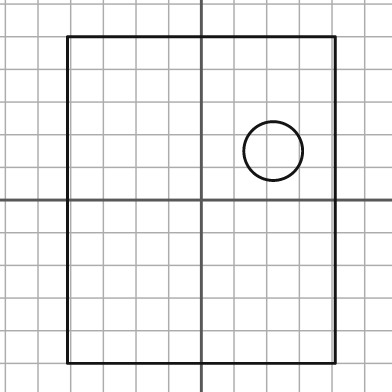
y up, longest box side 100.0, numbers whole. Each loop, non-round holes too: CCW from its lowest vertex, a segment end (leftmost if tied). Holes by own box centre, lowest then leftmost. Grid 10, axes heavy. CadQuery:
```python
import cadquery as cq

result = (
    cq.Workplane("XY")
    .moveTo(-41.0, -50.0)
    .lineTo(41.0, -50.0)
    .lineTo(41.0, 50.0)
    .lineTo(-41.0, 50.0)
    .close()
    .moveTo(22.0, 15.0)
    .circle(9.0)
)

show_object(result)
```